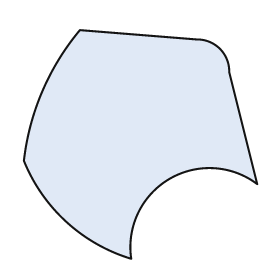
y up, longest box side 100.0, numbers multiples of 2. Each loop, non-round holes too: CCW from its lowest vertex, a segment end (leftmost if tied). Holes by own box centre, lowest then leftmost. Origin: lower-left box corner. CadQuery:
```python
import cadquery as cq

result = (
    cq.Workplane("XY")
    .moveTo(46.0, 0.0)
    .threePointArc((62.0, 34.0), (100.0, 32.0))
    .lineTo(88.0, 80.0)
    .threePointArc((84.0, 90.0), (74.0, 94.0))
    .lineTo(24.0, 98.0)
    .threePointArc((8.0, 72.0), (0.0, 42.0))
    .threePointArc((18.0, 16.0), (46.0, 0.0))
    .close()
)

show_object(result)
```